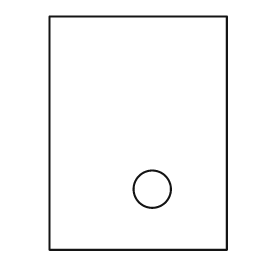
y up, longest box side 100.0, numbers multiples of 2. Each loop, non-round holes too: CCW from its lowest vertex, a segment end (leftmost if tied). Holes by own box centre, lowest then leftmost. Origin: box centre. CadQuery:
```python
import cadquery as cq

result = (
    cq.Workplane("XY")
    .moveTo(-38.0, -50.0)
    .lineTo(38.0, -50.0)
    .lineTo(38.0, 50.0)
    .lineTo(-38.0, 50.0)
    .close()
    .moveTo(6.0, -24.0)
    .circle(8.0)
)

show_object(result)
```